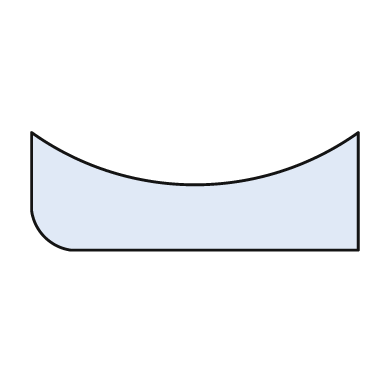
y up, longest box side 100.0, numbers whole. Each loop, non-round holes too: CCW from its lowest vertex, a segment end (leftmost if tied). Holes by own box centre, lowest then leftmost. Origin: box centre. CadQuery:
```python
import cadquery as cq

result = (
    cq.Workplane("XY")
    .moveTo(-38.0, -18.0)
    .lineTo(50.0, -18.0)
    .lineTo(50.0, 18.0)
    .threePointArc((0.0, 2.0), (-50.0, 18.0))
    .lineTo(-50.0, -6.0)
    .threePointArc((-46.0, -14.0), (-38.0, -18.0))
    .close()
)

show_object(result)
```